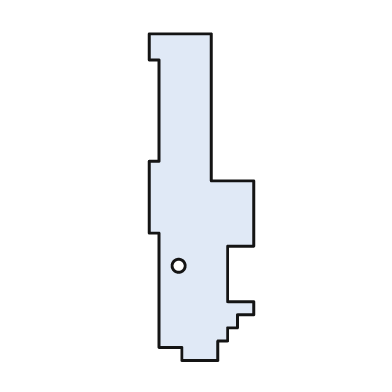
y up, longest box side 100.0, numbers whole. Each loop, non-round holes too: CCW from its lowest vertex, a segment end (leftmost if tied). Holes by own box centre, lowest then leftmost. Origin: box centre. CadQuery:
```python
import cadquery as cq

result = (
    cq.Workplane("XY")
    .moveTo(-6.0, -50.0)
    .lineTo(5.0, -50.0)
    .lineTo(5.0, -44.0)
    .lineTo(8.0, -44.0)
    .lineTo(8.0, -40.0)
    .lineTo(11.0, -40.0)
    .lineTo(11.0, -36.0)
    .lineTo(16.0, -36.0)
    .lineTo(16.0, -32.0)
    .lineTo(8.0, -32.0)
    .lineTo(8.0, -15.0)
    .lineTo(16.0, -15.0)
    .lineTo(16.0, 5.0)
    .lineTo(3.0, 5.0)
    .lineTo(3.0, 50.0)
    .lineTo(-16.0, 50.0)
    .lineTo(-16.0, 42.0)
    .lineTo(-13.0, 42.0)
    .lineTo(-13.0, 11.0)
    .lineTo(-16.0, 11.0)
    .lineTo(-16.0, -11.0)
    .lineTo(-13.0, -11.0)
    .lineTo(-13.0, -46.0)
    .lineTo(-6.0, -46.0)
    .close()
    .moveTo(-7.0, -21.0)
    .circle(2.0)
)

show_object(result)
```